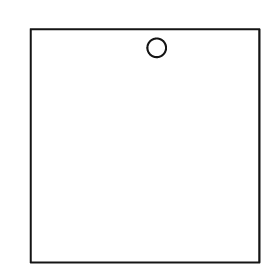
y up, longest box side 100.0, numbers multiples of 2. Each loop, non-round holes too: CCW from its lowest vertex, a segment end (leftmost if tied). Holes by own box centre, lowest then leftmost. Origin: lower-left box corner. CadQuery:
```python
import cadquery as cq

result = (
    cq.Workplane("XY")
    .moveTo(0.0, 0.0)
    .lineTo(98.0, 0.0)
    .lineTo(98.0, 100.0)
    .lineTo(0.0, 100.0)
    .close()
    .moveTo(54.0, 92.0)
    .circle(4.0)
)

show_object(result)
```